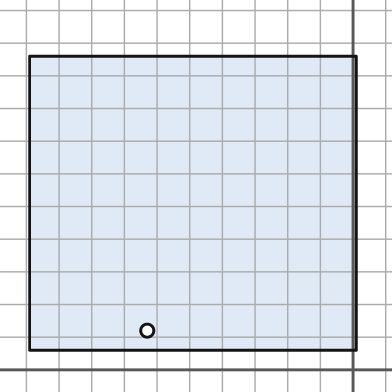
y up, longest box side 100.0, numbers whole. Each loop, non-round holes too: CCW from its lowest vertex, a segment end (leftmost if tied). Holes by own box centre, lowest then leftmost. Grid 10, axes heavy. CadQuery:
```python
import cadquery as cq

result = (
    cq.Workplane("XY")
    .moveTo(-99.0, 6.0)
    .lineTo(1.0, 6.0)
    .lineTo(1.0, 96.0)
    .lineTo(-99.0, 96.0)
    .close()
    .moveTo(-63.0, 12.0)
    .circle(2.0)
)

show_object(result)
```